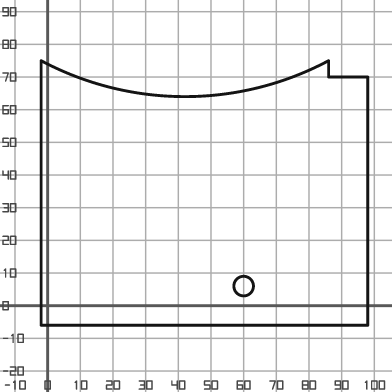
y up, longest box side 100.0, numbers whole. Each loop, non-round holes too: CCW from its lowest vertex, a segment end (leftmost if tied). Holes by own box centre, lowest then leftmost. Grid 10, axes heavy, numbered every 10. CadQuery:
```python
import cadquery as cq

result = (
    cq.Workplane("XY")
    .moveTo(-2.0, -6.0)
    .lineTo(98.0, -6.0)
    .lineTo(98.0, 70.0)
    .lineTo(86.0, 70.0)
    .lineTo(86.0, 75.0)
    .threePointArc((42.0, 64.0), (-2.0, 75.0))
    .close()
    .moveTo(60.0, 6.0)
    .circle(3.0)
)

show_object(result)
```